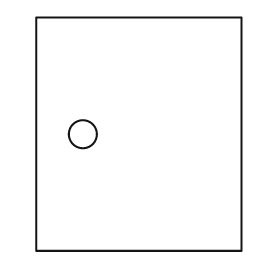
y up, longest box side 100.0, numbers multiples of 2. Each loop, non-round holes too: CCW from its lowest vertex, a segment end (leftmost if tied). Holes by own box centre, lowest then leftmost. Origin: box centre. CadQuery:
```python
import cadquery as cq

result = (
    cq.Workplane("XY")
    .moveTo(-44.0, -50.0)
    .lineTo(44.0, -50.0)
    .lineTo(44.0, 50.0)
    .lineTo(-44.0, 50.0)
    .close()
    .moveTo(-24.0, 0.0)
    .circle(6.0)
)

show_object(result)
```